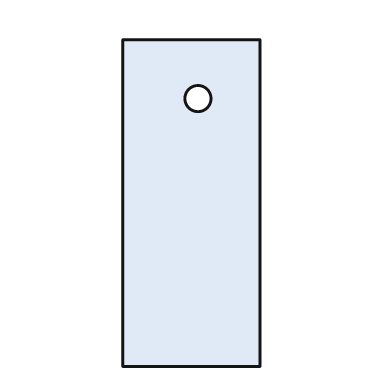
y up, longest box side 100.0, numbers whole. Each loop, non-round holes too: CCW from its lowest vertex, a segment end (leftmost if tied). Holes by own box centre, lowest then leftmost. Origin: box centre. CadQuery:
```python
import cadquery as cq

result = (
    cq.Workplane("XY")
    .moveTo(-21.0, -50.0)
    .lineTo(21.0, -50.0)
    .lineTo(21.0, 50.0)
    .lineTo(-21.0, 50.0)
    .close()
    .moveTo(2.0, 32.0)
    .circle(4.0)
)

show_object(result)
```